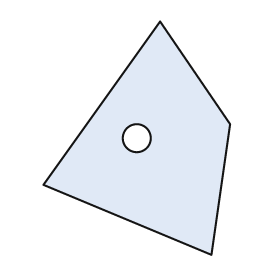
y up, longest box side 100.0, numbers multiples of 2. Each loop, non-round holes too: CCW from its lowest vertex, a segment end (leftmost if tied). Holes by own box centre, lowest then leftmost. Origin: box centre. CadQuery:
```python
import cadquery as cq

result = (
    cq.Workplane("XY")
    .moveTo(32.0, -50.0)
    .lineTo(40.0, 6.0)
    .lineTo(10.0, 50.0)
    .lineTo(-40.0, -20.0)
    .close()
    .moveTo(0.0, 0.0)
    .circle(6.0)
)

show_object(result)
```